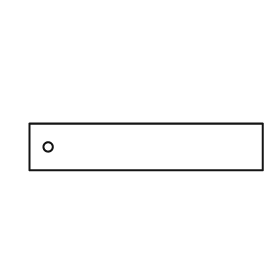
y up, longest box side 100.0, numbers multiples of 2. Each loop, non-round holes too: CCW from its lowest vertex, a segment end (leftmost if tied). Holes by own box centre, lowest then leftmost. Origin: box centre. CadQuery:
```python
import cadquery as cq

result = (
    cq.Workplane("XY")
    .moveTo(-50.0, -10.0)
    .lineTo(50.0, -10.0)
    .lineTo(50.0, 10.0)
    .lineTo(-50.0, 10.0)
    .close()
    .moveTo(-42.0, 0.0)
    .circle(2.0)
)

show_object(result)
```